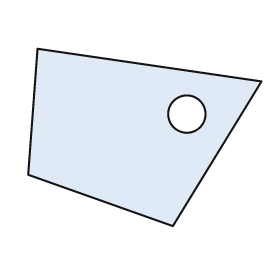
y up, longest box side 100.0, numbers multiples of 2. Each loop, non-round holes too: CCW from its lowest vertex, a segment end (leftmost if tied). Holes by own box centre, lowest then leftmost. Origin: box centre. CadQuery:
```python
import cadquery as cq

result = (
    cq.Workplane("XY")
    .moveTo(12.0, -38.0)
    .lineTo(50.0, 24.0)
    .lineTo(-46.0, 38.0)
    .lineTo(-50.0, -16.0)
    .close()
    .moveTo(18.0, 10.0)
    .circle(8.0)
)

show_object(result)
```